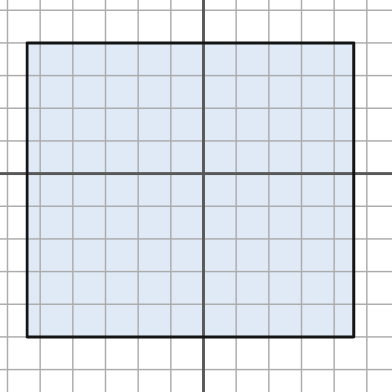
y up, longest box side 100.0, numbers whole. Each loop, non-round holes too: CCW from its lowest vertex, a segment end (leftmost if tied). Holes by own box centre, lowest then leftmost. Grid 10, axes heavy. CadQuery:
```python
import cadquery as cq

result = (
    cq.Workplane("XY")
    .moveTo(-54.0, -50.0)
    .lineTo(46.0, -50.0)
    .lineTo(46.0, 40.0)
    .lineTo(-54.0, 40.0)
    .close()
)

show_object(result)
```